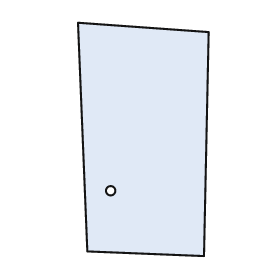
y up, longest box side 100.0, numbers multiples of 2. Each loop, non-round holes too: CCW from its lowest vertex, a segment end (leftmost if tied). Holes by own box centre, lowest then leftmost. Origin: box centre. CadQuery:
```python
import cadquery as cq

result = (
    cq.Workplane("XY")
    .moveTo(26.0, -50.0)
    .lineTo(28.0, 46.0)
    .lineTo(-28.0, 50.0)
    .lineTo(-24.0, -48.0)
    .close()
    .moveTo(-14.0, -22.0)
    .circle(2.0)
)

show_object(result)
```